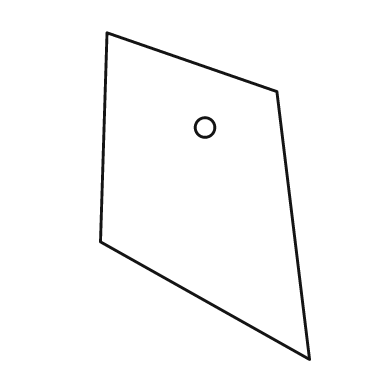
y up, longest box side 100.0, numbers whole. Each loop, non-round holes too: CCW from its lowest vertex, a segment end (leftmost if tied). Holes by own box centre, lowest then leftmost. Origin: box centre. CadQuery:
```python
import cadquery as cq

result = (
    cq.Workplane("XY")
    .moveTo(32.0, -50.0)
    .lineTo(22.0, 32.0)
    .lineTo(-30.0, 50.0)
    .lineTo(-32.0, -14.0)
    .close()
    .moveTo(0.0, 21.0)
    .circle(3.0)
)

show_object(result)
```